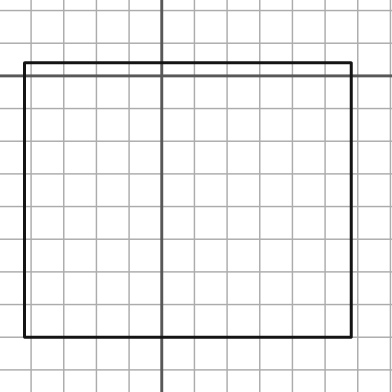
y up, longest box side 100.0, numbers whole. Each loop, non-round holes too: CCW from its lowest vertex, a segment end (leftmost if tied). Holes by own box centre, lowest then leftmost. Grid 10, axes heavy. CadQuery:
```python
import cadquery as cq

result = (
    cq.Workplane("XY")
    .moveTo(-42.0, -80.0)
    .lineTo(58.0, -80.0)
    .lineTo(58.0, 4.0)
    .lineTo(-42.0, 4.0)
    .close()
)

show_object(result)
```